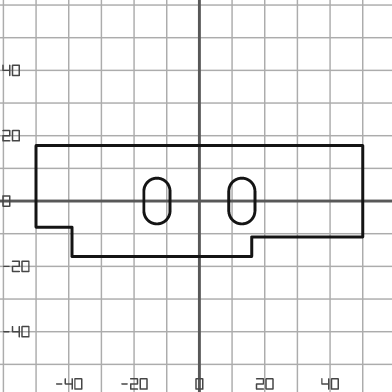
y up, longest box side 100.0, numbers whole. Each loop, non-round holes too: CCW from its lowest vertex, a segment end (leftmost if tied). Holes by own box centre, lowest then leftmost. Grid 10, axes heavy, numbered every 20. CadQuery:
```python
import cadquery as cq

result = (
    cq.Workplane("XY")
    .moveTo(-39.0, -17.0)
    .lineTo(16.0, -17.0)
    .lineTo(16.0, -11.0)
    .lineTo(50.0, -11.0)
    .lineTo(50.0, 17.0)
    .lineTo(-50.0, 17.0)
    .lineTo(-50.0, -8.0)
    .lineTo(-39.0, -8.0)
    .close()
    .moveTo(-17.0, -3.0)
    .threePointArc((-13.0, -7.0), (-9.0, -3.0))
    .lineTo(-9.0, 3.0)
    .threePointArc((-13.0, 7.0), (-17.0, 3.0))
    .close()
    .moveTo(9.0, -3.0)
    .threePointArc((13.0, -7.0), (17.0, -3.0))
    .lineTo(17.0, 3.0)
    .threePointArc((13.0, 7.0), (9.0, 3.0))
    .close()
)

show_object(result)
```